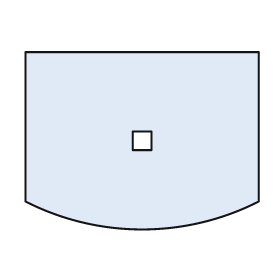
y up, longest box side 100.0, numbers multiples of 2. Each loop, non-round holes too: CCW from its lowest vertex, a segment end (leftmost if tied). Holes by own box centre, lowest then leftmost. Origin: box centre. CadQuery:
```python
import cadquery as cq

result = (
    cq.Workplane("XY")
    .moveTo(-50.0, -26.0)
    .threePointArc((0.0, -38.0), (50.0, -26.0))
    .lineTo(50.0, 38.0)
    .lineTo(-50.0, 38.0)
    .close()
    .moveTo(-4.0, -4.0)
    .lineTo(4.0, -4.0)
    .lineTo(4.0, 4.0)
    .lineTo(-4.0, 4.0)
    .close()
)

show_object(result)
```